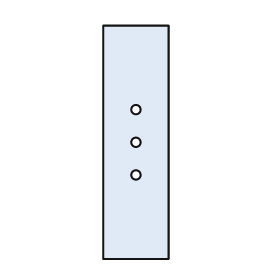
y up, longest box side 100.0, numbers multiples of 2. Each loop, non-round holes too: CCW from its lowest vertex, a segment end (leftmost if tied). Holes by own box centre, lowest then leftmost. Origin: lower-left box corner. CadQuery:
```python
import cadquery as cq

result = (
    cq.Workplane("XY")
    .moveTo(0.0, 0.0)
    .lineTo(28.0, 0.0)
    .lineTo(28.0, 100.0)
    .lineTo(0.0, 100.0)
    .close()
    .moveTo(14.0, 36.0)
    .circle(2.0)
    .moveTo(14.0, 50.0)
    .circle(2.0)
    .moveTo(14.0, 64.0)
    .circle(2.0)
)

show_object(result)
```